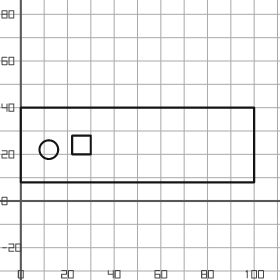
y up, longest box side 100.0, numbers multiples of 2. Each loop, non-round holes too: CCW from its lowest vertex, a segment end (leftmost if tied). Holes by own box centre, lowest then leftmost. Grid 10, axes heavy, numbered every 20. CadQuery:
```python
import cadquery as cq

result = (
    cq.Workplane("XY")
    .moveTo(0.0, 8.0)
    .lineTo(100.0, 8.0)
    .lineTo(100.0, 40.0)
    .lineTo(0.0, 40.0)
    .close()
    .moveTo(12.0, 22.0)
    .circle(4.0)
    .moveTo(22.0, 20.0)
    .lineTo(30.0, 20.0)
    .lineTo(30.0, 28.0)
    .lineTo(22.0, 28.0)
    .close()
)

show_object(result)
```